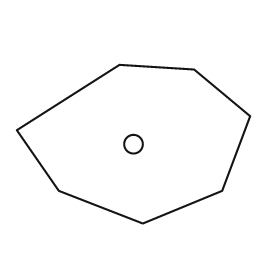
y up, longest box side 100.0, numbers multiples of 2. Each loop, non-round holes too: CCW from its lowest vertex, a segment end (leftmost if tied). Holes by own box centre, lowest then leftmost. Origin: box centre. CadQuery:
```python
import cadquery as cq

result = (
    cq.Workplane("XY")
    .moveTo(4.0, -34.0)
    .lineTo(38.0, -20.0)
    .lineTo(50.0, 12.0)
    .lineTo(26.0, 32.0)
    .lineTo(-6.0, 34.0)
    .lineTo(-50.0, 6.0)
    .lineTo(-32.0, -20.0)
    .close()
    .moveTo(0.0, 0.0)
    .circle(4.0)
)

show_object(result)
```